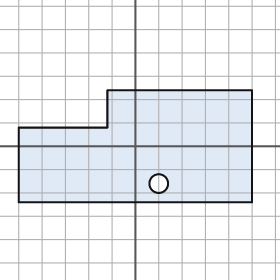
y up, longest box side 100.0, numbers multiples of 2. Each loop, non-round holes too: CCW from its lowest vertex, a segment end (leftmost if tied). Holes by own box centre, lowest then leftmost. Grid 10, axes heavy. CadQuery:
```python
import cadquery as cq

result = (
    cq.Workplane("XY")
    .moveTo(-50.0, -24.0)
    .lineTo(50.0, -24.0)
    .lineTo(50.0, 24.0)
    .lineTo(-12.0, 24.0)
    .lineTo(-12.0, 8.0)
    .lineTo(-50.0, 8.0)
    .close()
    .moveTo(10.0, -16.0)
    .circle(4.0)
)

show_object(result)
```